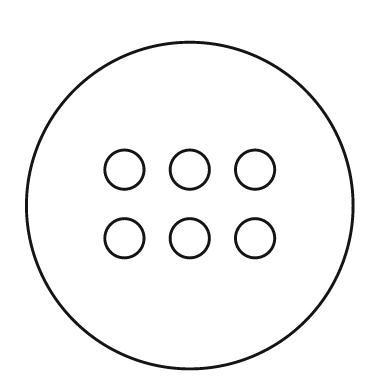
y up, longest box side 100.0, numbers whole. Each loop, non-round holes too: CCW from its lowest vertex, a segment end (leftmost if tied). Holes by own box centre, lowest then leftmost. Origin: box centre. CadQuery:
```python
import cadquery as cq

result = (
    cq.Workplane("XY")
    .moveTo(0.0, 0.0)
    .circle(50.0)
    .moveTo(-20.0, -10.0)
    .circle(6.0)
    .moveTo(0.0, -10.0)
    .circle(6.0)
    .moveTo(20.0, -10.0)
    .circle(6.0)
    .moveTo(-20.0, 11.0)
    .circle(6.0)
    .moveTo(0.0, 11.0)
    .circle(6.0)
    .moveTo(20.0, 11.0)
    .circle(6.0)
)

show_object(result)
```